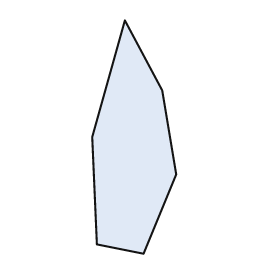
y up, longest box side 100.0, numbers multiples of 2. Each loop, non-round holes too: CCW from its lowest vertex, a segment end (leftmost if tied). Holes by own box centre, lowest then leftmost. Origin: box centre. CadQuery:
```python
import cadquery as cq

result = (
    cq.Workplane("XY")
    .moveTo(4.0, -50.0)
    .lineTo(18.0, -16.0)
    .lineTo(12.0, 20.0)
    .lineTo(-4.0, 50.0)
    .lineTo(-18.0, 0.0)
    .lineTo(-16.0, -46.0)
    .close()
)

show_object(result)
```